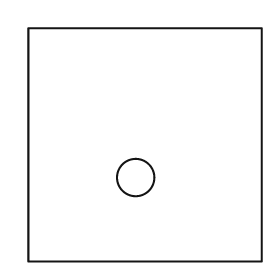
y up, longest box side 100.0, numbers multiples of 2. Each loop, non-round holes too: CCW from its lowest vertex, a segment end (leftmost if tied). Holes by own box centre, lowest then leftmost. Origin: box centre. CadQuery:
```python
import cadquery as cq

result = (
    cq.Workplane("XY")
    .moveTo(-50.0, -50.0)
    .lineTo(50.0, -50.0)
    .lineTo(50.0, 50.0)
    .lineTo(-50.0, 50.0)
    .close()
    .moveTo(-4.0, -14.0)
    .circle(8.0)
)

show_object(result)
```